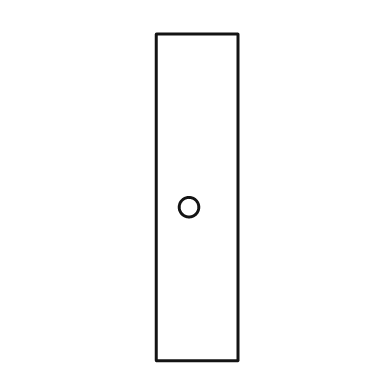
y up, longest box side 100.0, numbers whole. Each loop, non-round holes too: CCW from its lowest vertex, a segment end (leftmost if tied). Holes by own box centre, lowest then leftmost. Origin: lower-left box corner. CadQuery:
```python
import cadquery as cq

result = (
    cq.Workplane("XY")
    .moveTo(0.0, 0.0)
    .lineTo(25.0, 0.0)
    .lineTo(25.0, 100.0)
    .lineTo(0.0, 100.0)
    .close()
    .moveTo(10.0, 47.0)
    .circle(3.0)
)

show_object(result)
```